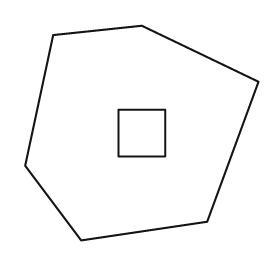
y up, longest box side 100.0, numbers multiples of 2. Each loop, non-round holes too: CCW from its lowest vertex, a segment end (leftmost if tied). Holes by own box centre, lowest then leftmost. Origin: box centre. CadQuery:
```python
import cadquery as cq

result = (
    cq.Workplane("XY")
    .moveTo(-26.0, -46.0)
    .lineTo(28.0, -38.0)
    .lineTo(50.0, 22.0)
    .lineTo(0.0, 46.0)
    .lineTo(-38.0, 42.0)
    .lineTo(-50.0, -14.0)
    .close()
    .moveTo(-10.0, -10.0)
    .lineTo(10.0, -10.0)
    .lineTo(10.0, 10.0)
    .lineTo(-10.0, 10.0)
    .close()
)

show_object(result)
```